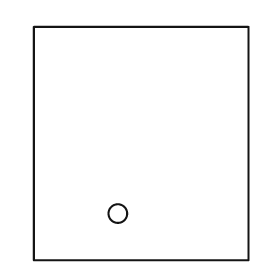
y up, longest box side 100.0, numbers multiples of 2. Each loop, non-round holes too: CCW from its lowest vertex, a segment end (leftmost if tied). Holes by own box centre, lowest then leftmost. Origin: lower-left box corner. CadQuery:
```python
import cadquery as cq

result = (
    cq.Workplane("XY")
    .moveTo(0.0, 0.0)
    .lineTo(92.0, 0.0)
    .lineTo(92.0, 100.0)
    .lineTo(0.0, 100.0)
    .close()
    .moveTo(36.0, 20.0)
    .circle(4.0)
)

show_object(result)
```